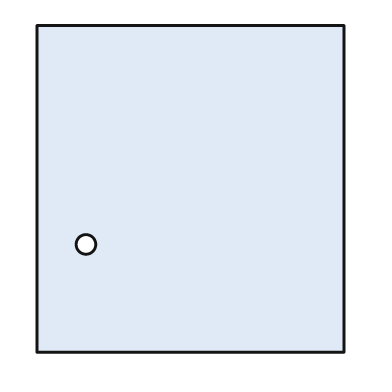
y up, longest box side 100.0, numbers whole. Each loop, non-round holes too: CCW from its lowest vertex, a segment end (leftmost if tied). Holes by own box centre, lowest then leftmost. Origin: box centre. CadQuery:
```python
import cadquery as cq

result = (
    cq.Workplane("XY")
    .moveTo(-47.0, -50.0)
    .lineTo(47.0, -50.0)
    .lineTo(47.0, 50.0)
    .lineTo(-47.0, 50.0)
    .close()
    .moveTo(-32.0, -17.0)
    .circle(3.0)
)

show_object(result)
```